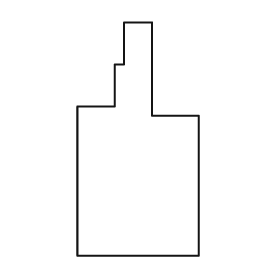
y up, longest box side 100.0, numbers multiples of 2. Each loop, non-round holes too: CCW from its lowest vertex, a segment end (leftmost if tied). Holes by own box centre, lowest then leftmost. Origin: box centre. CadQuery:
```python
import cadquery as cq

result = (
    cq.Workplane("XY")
    .moveTo(-26.0, -50.0)
    .lineTo(26.0, -50.0)
    .lineTo(26.0, 10.0)
    .lineTo(6.0, 10.0)
    .lineTo(6.0, 50.0)
    .lineTo(-6.0, 50.0)
    .lineTo(-6.0, 32.0)
    .lineTo(-10.0, 32.0)
    .lineTo(-10.0, 14.0)
    .lineTo(-26.0, 14.0)
    .close()
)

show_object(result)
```